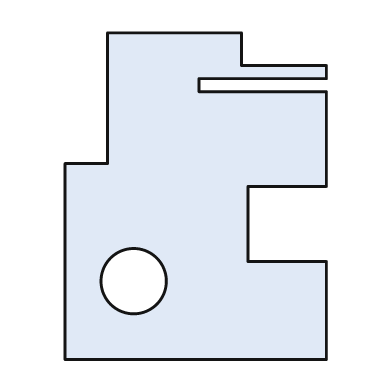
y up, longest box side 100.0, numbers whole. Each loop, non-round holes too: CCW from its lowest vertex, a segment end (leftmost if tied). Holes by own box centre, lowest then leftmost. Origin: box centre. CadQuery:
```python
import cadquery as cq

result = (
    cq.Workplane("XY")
    .moveTo(-40.0, -50.0)
    .lineTo(40.0, -50.0)
    .lineTo(40.0, -20.0)
    .lineTo(16.0, -20.0)
    .lineTo(16.0, 3.0)
    .lineTo(40.0, 3.0)
    .lineTo(40.0, 32.0)
    .lineTo(1.0, 32.0)
    .lineTo(1.0, 36.0)
    .lineTo(40.0, 36.0)
    .lineTo(40.0, 40.0)
    .lineTo(14.0, 40.0)
    .lineTo(14.0, 50.0)
    .lineTo(-27.0, 50.0)
    .lineTo(-27.0, 10.0)
    .lineTo(-40.0, 10.0)
    .close()
    .moveTo(-19.0, -26.0)
    .circle(10.0)
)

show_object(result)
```